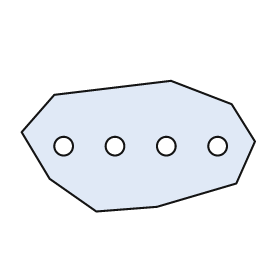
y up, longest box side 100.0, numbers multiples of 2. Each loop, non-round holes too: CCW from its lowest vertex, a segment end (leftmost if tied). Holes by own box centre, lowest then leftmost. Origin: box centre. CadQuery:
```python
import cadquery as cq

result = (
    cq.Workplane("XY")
    .moveTo(-18.0, -28.0)
    .lineTo(8.0, -26.0)
    .lineTo(42.0, -16.0)
    .lineTo(50.0, 2.0)
    .lineTo(40.0, 18.0)
    .lineTo(14.0, 28.0)
    .lineTo(-36.0, 22.0)
    .lineTo(-50.0, 6.0)
    .lineTo(-38.0, -14.0)
    .close()
    .moveTo(-32.0, 0.0)
    .circle(4.0)
    .moveTo(-10.0, 0.0)
    .circle(4.0)
    .moveTo(12.0, 0.0)
    .circle(4.0)
    .moveTo(34.0, 0.0)
    .circle(4.0)
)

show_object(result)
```